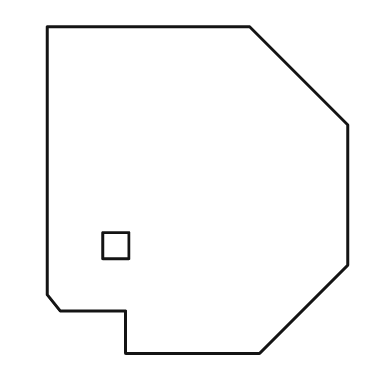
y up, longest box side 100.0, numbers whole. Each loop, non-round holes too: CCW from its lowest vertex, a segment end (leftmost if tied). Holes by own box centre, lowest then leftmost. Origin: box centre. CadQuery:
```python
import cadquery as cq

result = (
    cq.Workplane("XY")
    .moveTo(-22.0, -50.0)
    .lineTo(19.0, -50.0)
    .lineTo(46.0, -23.0)
    .lineTo(46.0, 20.0)
    .lineTo(16.0, 50.0)
    .lineTo(-46.0, 50.0)
    .lineTo(-46.0, -32.0)
    .lineTo(-42.0, -37.0)
    .lineTo(-22.0, -37.0)
    .close()
    .moveTo(-29.0, -21.0)
    .lineTo(-21.0, -21.0)
    .lineTo(-21.0, -13.0)
    .lineTo(-29.0, -13.0)
    .close()
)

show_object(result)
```